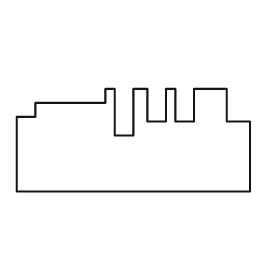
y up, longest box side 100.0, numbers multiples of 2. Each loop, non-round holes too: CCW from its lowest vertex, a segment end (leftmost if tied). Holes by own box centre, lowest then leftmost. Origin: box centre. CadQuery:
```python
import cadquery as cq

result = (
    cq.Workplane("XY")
    .moveTo(-50.0, -22.0)
    .lineTo(50.0, -22.0)
    .lineTo(50.0, 8.0)
    .lineTo(40.0, 8.0)
    .lineTo(40.0, 22.0)
    .lineTo(26.0, 22.0)
    .lineTo(26.0, 8.0)
    .lineTo(18.0, 8.0)
    .lineTo(18.0, 22.0)
    .lineTo(14.0, 22.0)
    .lineTo(14.0, 8.0)
    .lineTo(6.0, 8.0)
    .lineTo(6.0, 22.0)
    .lineTo(0.0, 22.0)
    .lineTo(0.0, 2.0)
    .lineTo(-8.0, 2.0)
    .lineTo(-8.0, 22.0)
    .lineTo(-12.0, 22.0)
    .lineTo(-12.0, 16.0)
    .lineTo(-42.0, 16.0)
    .lineTo(-42.0, 10.0)
    .lineTo(-50.0, 10.0)
    .close()
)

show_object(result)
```